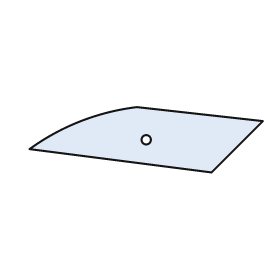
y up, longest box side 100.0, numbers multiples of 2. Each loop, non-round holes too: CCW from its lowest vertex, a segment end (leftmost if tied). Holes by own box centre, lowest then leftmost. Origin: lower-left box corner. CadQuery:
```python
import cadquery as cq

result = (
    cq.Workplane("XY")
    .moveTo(78.0, 0.0)
    .lineTo(100.0, 22.0)
    .lineTo(46.0, 28.0)
    .threePointArc((22.0, 22.0), (0.0, 10.0))
    .close()
    .moveTo(50.0, 14.0)
    .circle(2.0)
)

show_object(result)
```